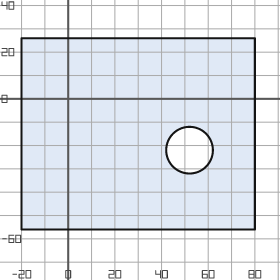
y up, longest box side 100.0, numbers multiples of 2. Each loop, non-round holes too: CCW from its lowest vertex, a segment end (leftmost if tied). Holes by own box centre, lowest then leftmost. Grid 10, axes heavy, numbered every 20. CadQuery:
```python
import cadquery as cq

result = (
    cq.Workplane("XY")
    .moveTo(-20.0, -56.0)
    .lineTo(80.0, -56.0)
    .lineTo(80.0, 26.0)
    .lineTo(-20.0, 26.0)
    .close()
    .moveTo(52.0, -22.0)
    .circle(10.0)
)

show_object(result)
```